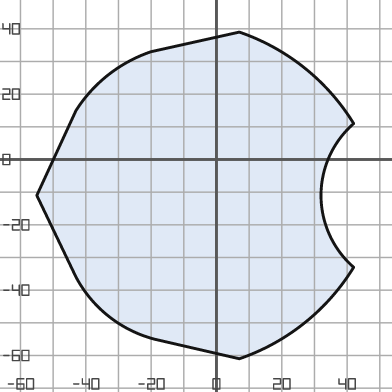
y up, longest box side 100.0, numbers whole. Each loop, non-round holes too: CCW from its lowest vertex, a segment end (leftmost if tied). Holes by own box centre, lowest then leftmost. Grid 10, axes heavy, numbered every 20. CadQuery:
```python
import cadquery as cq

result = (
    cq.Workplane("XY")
    .moveTo(7.0, -61.0)
    .threePointArc((27.0, -50.0), (42.0, -33.0))
    .threePointArc((32.0, -11.0), (42.0, 11.0))
    .threePointArc((27.0, 28.0), (7.0, 39.0))
    .lineTo(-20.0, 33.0)
    .threePointArc((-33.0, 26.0), (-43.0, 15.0))
    .lineTo(-55.0, -11.0)
    .lineTo(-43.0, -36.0)
    .threePointArc((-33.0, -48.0), (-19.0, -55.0))
    .close()
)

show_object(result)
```